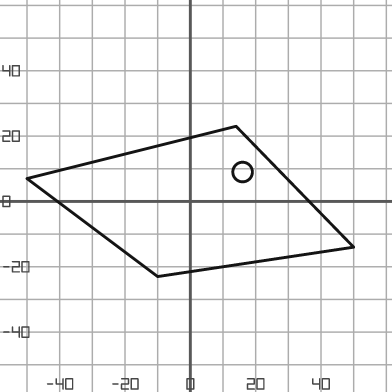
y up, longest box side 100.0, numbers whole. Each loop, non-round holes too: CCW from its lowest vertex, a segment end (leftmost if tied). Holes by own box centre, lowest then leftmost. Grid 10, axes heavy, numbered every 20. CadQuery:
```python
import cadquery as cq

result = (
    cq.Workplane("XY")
    .moveTo(-10.0, -23.0)
    .lineTo(50.0, -14.0)
    .lineTo(14.0, 23.0)
    .lineTo(-50.0, 7.0)
    .close()
    .moveTo(16.0, 9.0)
    .circle(3.0)
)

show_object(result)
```